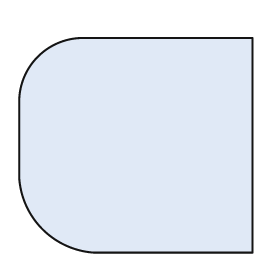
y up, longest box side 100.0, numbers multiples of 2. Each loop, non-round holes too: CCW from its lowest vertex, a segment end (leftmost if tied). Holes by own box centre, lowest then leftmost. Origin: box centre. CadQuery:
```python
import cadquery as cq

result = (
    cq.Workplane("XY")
    .moveTo(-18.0, -46.0)
    .lineTo(50.0, -46.0)
    .lineTo(50.0, 46.0)
    .lineTo(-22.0, 46.0)
    .threePointArc((-42.0, 38.0), (-50.0, 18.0))
    .lineTo(-50.0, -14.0)
    .threePointArc((-40.0, -36.0), (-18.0, -46.0))
    .close()
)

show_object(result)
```